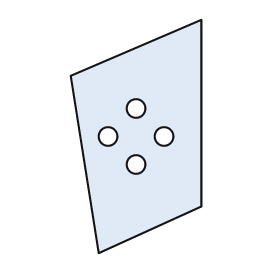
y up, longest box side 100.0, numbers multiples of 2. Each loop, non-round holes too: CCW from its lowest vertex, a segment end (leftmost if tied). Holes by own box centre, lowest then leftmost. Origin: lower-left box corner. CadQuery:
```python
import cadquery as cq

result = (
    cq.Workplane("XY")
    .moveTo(12.0, 0.0)
    .lineTo(56.0, 20.0)
    .lineTo(56.0, 100.0)
    .lineTo(0.0, 76.0)
    .close()
    .moveTo(28.0, 38.0)
    .circle(4.0)
    .moveTo(16.0, 50.0)
    .circle(4.0)
    .moveTo(40.0, 50.0)
    .circle(4.0)
    .moveTo(28.0, 62.0)
    .circle(4.0)
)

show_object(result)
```